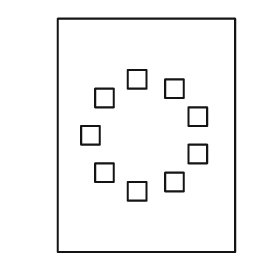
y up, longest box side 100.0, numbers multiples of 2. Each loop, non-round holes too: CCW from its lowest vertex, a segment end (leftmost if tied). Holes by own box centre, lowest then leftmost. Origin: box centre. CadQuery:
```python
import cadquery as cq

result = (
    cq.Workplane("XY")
    .moveTo(-38.0, -50.0)
    .lineTo(38.0, -50.0)
    .lineTo(38.0, 50.0)
    .lineTo(-38.0, 50.0)
    .close()
    .moveTo(-8.0, -28.0)
    .lineTo(0.0, -28.0)
    .lineTo(0.0, -20.0)
    .lineTo(-8.0, -20.0)
    .close()
    .moveTo(8.0, -24.0)
    .lineTo(16.0, -24.0)
    .lineTo(16.0, -16.0)
    .lineTo(8.0, -16.0)
    .close()
    .moveTo(-22.0, -20.0)
    .lineTo(-14.0, -20.0)
    .lineTo(-14.0, -12.0)
    .lineTo(-22.0, -12.0)
    .close()
    .moveTo(18.0, -12.0)
    .lineTo(26.0, -12.0)
    .lineTo(26.0, -4.0)
    .lineTo(18.0, -4.0)
    .close()
    .moveTo(-28.0, -4.0)
    .lineTo(-20.0, -4.0)
    .lineTo(-20.0, 4.0)
    .lineTo(-28.0, 4.0)
    .close()
    .moveTo(18.0, 4.0)
    .lineTo(26.0, 4.0)
    .lineTo(26.0, 12.0)
    .lineTo(18.0, 12.0)
    .close()
    .moveTo(-22.0, 12.0)
    .lineTo(-14.0, 12.0)
    .lineTo(-14.0, 20.0)
    .lineTo(-22.0, 20.0)
    .close()
    .moveTo(8.0, 16.0)
    .lineTo(16.0, 16.0)
    .lineTo(16.0, 24.0)
    .lineTo(8.0, 24.0)
    .close()
    .moveTo(-8.0, 20.0)
    .lineTo(0.0, 20.0)
    .lineTo(0.0, 28.0)
    .lineTo(-8.0, 28.0)
    .close()
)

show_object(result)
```